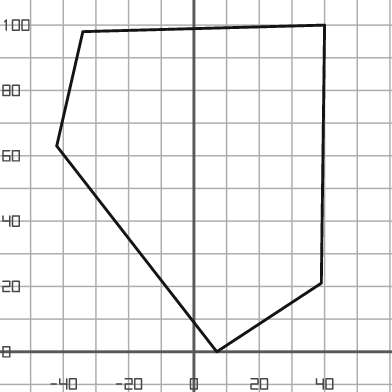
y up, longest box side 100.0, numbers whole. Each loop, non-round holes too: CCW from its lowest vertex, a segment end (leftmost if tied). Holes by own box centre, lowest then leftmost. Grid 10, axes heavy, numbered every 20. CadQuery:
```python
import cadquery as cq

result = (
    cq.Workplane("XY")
    .moveTo(7.0, 0.0)
    .lineTo(39.0, 21.0)
    .lineTo(40.0, 100.0)
    .lineTo(-34.0, 98.0)
    .lineTo(-42.0, 63.0)
    .close()
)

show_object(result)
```